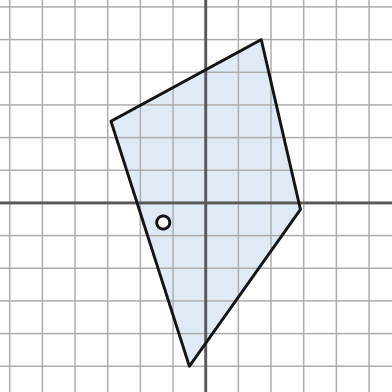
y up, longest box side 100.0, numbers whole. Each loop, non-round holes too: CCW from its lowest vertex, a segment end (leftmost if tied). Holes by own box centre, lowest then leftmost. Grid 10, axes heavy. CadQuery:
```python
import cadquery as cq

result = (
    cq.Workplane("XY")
    .moveTo(-5.0, -50.0)
    .lineTo(29.0, -2.0)
    .lineTo(17.0, 50.0)
    .lineTo(-29.0, 25.0)
    .close()
    .moveTo(-13.0, -6.0)
    .circle(2.0)
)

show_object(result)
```